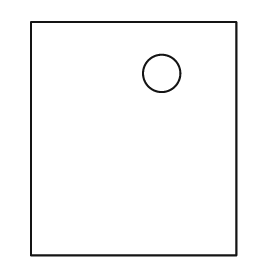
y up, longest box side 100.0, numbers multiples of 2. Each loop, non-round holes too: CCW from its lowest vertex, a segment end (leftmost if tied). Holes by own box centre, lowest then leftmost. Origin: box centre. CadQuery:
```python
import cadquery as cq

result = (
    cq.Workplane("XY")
    .moveTo(-44.0, -50.0)
    .lineTo(44.0, -50.0)
    .lineTo(44.0, 50.0)
    .lineTo(-44.0, 50.0)
    .close()
    .moveTo(12.0, 28.0)
    .circle(8.0)
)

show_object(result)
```